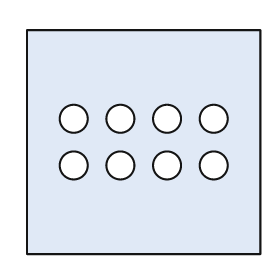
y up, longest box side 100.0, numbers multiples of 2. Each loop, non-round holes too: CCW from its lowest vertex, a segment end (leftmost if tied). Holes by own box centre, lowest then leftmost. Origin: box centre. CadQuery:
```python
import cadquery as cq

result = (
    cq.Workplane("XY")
    .moveTo(-50.0, -48.0)
    .lineTo(50.0, -48.0)
    .lineTo(50.0, 48.0)
    .lineTo(-50.0, 48.0)
    .close()
    .moveTo(-30.0, -10.0)
    .circle(6.0)
    .moveTo(-10.0, -10.0)
    .circle(6.0)
    .moveTo(10.0, -10.0)
    .circle(6.0)
    .moveTo(30.0, -10.0)
    .circle(6.0)
    .moveTo(-30.0, 10.0)
    .circle(6.0)
    .moveTo(-10.0, 10.0)
    .circle(6.0)
    .moveTo(10.0, 10.0)
    .circle(6.0)
    .moveTo(30.0, 10.0)
    .circle(6.0)
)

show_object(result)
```